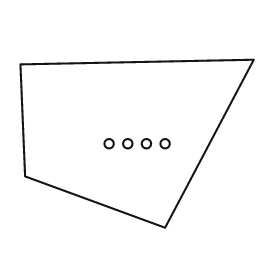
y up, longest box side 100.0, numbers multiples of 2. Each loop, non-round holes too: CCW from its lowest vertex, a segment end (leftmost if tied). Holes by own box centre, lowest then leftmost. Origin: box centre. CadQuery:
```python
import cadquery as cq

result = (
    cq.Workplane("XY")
    .moveTo(12.0, -36.0)
    .lineTo(50.0, 36.0)
    .lineTo(-50.0, 34.0)
    .lineTo(-48.0, -14.0)
    .close()
    .moveTo(-12.0, 0.0)
    .circle(2.0)
    .moveTo(-4.0, 0.0)
    .circle(2.0)
    .moveTo(4.0, 0.0)
    .circle(2.0)
    .moveTo(12.0, 0.0)
    .circle(2.0)
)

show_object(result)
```